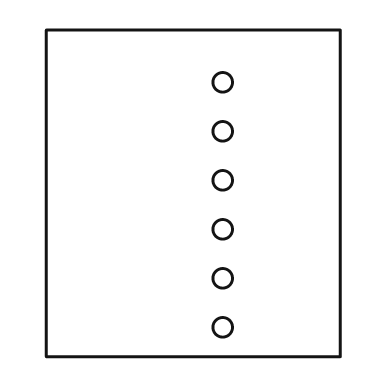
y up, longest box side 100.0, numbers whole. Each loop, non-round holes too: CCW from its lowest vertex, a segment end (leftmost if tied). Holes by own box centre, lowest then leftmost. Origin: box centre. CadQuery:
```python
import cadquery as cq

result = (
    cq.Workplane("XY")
    .moveTo(-45.0, -50.0)
    .lineTo(45.0, -50.0)
    .lineTo(45.0, 50.0)
    .lineTo(-45.0, 50.0)
    .close()
    .moveTo(9.0, -41.0)
    .circle(3.0)
    .moveTo(9.0, -26.0)
    .circle(3.0)
    .moveTo(9.0, -11.0)
    .circle(3.0)
    .moveTo(9.0, 4.0)
    .circle(3.0)
    .moveTo(9.0, 19.0)
    .circle(3.0)
    .moveTo(9.0, 34.0)
    .circle(3.0)
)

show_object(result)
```